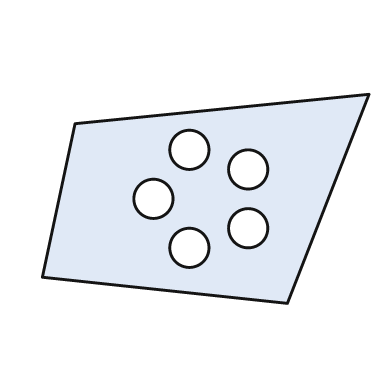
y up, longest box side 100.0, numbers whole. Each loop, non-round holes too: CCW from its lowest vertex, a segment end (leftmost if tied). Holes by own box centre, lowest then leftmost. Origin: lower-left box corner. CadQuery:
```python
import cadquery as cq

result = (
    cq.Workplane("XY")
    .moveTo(75.0, 0.0)
    .lineTo(100.0, 64.0)
    .lineTo(10.0, 55.0)
    .lineTo(0.0, 8.0)
    .close()
    .moveTo(45.0, 17.0)
    .circle(6.0)
    .moveTo(63.0, 23.0)
    .circle(6.0)
    .moveTo(34.0, 32.0)
    .circle(6.0)
    .moveTo(63.0, 41.0)
    .circle(6.0)
    .moveTo(45.0, 47.0)
    .circle(6.0)
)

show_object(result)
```